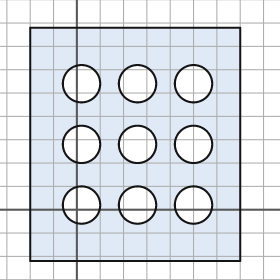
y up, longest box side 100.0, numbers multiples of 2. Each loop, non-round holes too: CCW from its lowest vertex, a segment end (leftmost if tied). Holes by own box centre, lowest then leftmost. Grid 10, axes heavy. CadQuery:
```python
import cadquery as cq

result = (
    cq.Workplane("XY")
    .moveTo(-20.0, -22.0)
    .lineTo(70.0, -22.0)
    .lineTo(70.0, 78.0)
    .lineTo(-20.0, 78.0)
    .close()
    .moveTo(2.0, 2.0)
    .circle(8.0)
    .moveTo(26.0, 2.0)
    .circle(8.0)
    .moveTo(50.0, 2.0)
    .circle(8.0)
    .moveTo(2.0, 28.0)
    .circle(8.0)
    .moveTo(26.0, 28.0)
    .circle(8.0)
    .moveTo(50.0, 28.0)
    .circle(8.0)
    .moveTo(2.0, 54.0)
    .circle(8.0)
    .moveTo(26.0, 54.0)
    .circle(8.0)
    .moveTo(50.0, 54.0)
    .circle(8.0)
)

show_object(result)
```